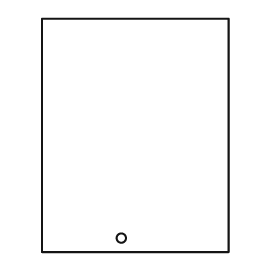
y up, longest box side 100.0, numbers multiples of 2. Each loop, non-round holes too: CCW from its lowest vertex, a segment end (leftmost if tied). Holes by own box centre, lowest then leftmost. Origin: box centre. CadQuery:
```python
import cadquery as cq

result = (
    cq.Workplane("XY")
    .moveTo(-40.0, -50.0)
    .lineTo(40.0, -50.0)
    .lineTo(40.0, 50.0)
    .lineTo(-40.0, 50.0)
    .close()
    .moveTo(-6.0, -44.0)
    .circle(2.0)
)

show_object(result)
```